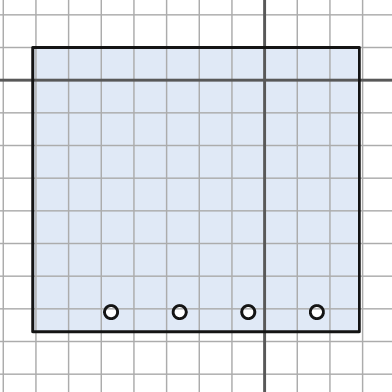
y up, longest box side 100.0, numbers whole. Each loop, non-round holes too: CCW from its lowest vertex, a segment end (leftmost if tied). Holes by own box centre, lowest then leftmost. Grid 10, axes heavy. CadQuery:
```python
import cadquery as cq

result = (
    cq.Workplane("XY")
    .moveTo(-71.0, -77.0)
    .lineTo(29.0, -77.0)
    .lineTo(29.0, 10.0)
    .lineTo(-71.0, 10.0)
    .close()
    .moveTo(-47.0, -71.0)
    .circle(2.0)
    .moveTo(-26.0, -71.0)
    .circle(2.0)
    .moveTo(-5.0, -71.0)
    .circle(2.0)
    .moveTo(16.0, -71.0)
    .circle(2.0)
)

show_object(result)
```